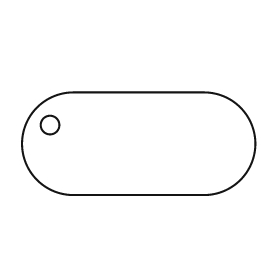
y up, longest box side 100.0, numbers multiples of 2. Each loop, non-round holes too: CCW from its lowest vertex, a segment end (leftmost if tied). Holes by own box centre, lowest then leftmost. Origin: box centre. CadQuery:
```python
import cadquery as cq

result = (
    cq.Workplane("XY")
    .moveTo(-28.0, -22.0)
    .lineTo(28.0, -22.0)
    .threePointArc((50.0, 0.0), (28.0, 22.0))
    .lineTo(-28.0, 22.0)
    .threePointArc((-50.0, 0.0), (-28.0, -22.0))
    .close()
    .moveTo(-38.0, 8.0)
    .circle(4.0)
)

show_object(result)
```